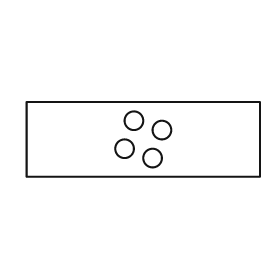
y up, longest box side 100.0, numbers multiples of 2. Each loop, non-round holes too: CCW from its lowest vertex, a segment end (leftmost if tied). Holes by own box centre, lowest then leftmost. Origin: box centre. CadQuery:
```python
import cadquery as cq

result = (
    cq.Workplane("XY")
    .moveTo(-50.0, -16.0)
    .lineTo(50.0, -16.0)
    .lineTo(50.0, 16.0)
    .lineTo(-50.0, 16.0)
    .close()
    .moveTo(4.0, -8.0)
    .circle(4.0)
    .moveTo(-8.0, -4.0)
    .circle(4.0)
    .moveTo(8.0, 4.0)
    .circle(4.0)
    .moveTo(-4.0, 8.0)
    .circle(4.0)
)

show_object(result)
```